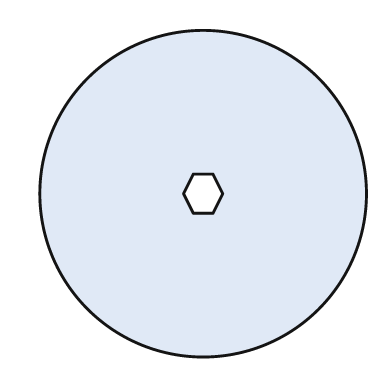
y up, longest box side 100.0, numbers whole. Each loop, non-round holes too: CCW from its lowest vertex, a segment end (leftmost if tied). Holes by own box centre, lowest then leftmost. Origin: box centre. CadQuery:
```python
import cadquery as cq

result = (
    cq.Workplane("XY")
    .moveTo(0.0, 0.0)
    .circle(50.0)
    .moveTo(-3.0, -6.0)
    .lineTo(3.0, -6.0)
    .lineTo(6.0, 0.0)
    .lineTo(3.0, 6.0)
    .lineTo(-3.0, 6.0)
    .lineTo(-6.0, 0.0)
    .close()
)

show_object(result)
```